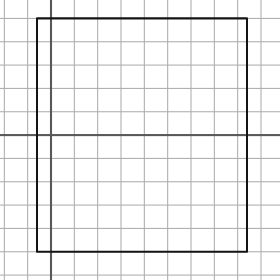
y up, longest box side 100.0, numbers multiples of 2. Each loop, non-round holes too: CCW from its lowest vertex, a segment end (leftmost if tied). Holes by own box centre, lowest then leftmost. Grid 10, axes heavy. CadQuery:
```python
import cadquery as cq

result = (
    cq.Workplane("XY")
    .moveTo(-6.0, -50.0)
    .lineTo(84.0, -50.0)
    .lineTo(84.0, 50.0)
    .lineTo(-6.0, 50.0)
    .close()
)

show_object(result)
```